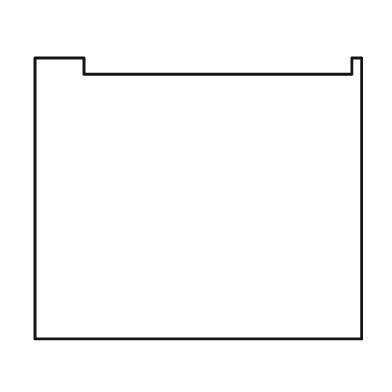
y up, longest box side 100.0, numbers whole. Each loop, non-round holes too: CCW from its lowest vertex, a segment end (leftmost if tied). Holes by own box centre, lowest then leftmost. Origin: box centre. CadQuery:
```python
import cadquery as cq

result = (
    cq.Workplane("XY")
    .moveTo(-50.0, -43.0)
    .lineTo(50.0, -43.0)
    .lineTo(50.0, 43.0)
    .lineTo(47.0, 43.0)
    .lineTo(47.0, 38.0)
    .lineTo(-35.0, 38.0)
    .lineTo(-35.0, 43.0)
    .lineTo(-50.0, 43.0)
    .close()
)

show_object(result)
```